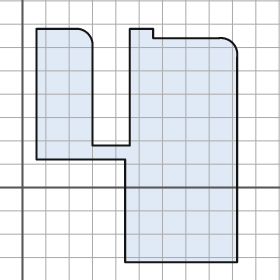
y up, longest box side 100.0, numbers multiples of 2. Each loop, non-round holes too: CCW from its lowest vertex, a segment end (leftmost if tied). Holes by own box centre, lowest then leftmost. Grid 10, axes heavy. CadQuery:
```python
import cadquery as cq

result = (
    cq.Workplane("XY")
    .moveTo(44.0, -32.0)
    .lineTo(92.0, -32.0)
    .lineTo(92.0, 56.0)
    .threePointArc((90.0, 62.0), (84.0, 64.0))
    .lineTo(56.0, 64.0)
    .lineTo(56.0, 68.0)
    .lineTo(46.0, 68.0)
    .lineTo(46.0, 18.0)
    .lineTo(30.0, 18.0)
    .lineTo(30.0, 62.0)
    .threePointArc((28.0, 66.0), (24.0, 68.0))
    .lineTo(6.0, 68.0)
    .lineTo(6.0, 12.0)
    .lineTo(44.0, 12.0)
    .close()
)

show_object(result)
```